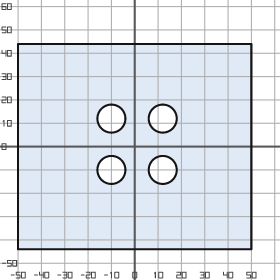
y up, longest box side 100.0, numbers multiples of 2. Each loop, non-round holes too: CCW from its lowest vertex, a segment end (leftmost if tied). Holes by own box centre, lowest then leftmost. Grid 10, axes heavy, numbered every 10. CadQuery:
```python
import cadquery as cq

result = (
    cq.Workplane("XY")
    .moveTo(-50.0, -44.0)
    .lineTo(50.0, -44.0)
    .lineTo(50.0, 44.0)
    .lineTo(-50.0, 44.0)
    .close()
    .moveTo(-10.0, -10.0)
    .circle(6.0)
    .moveTo(12.0, -10.0)
    .circle(6.0)
    .moveTo(-10.0, 12.0)
    .circle(6.0)
    .moveTo(12.0, 12.0)
    .circle(6.0)
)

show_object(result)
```